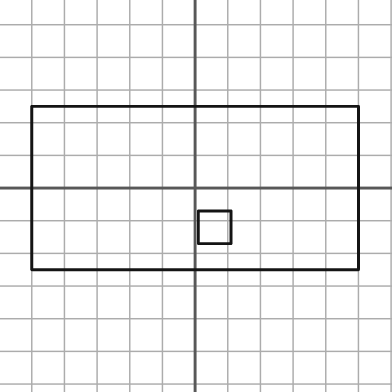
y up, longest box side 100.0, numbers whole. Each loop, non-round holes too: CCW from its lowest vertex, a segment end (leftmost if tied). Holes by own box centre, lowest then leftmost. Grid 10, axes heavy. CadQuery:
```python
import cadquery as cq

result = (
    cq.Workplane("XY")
    .moveTo(-50.0, -25.0)
    .lineTo(50.0, -25.0)
    .lineTo(50.0, 25.0)
    .lineTo(-50.0, 25.0)
    .close()
    .moveTo(1.0, -17.0)
    .lineTo(11.0, -17.0)
    .lineTo(11.0, -7.0)
    .lineTo(1.0, -7.0)
    .close()
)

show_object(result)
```